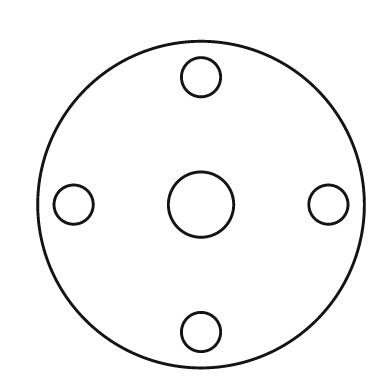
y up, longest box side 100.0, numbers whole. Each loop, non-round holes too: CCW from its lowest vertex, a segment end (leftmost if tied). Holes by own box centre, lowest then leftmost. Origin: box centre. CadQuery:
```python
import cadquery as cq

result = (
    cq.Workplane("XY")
    .moveTo(0.0, 0.0)
    .circle(50.0)
    .moveTo(0.0, -39.0)
    .circle(6.0)
    .moveTo(-39.0, 0.0)
    .circle(6.0)
    .moveTo(0.0, 0.0)
    .circle(10.0)
    .moveTo(39.0, 0.0)
    .circle(6.0)
    .moveTo(0.0, 39.0)
    .circle(6.0)
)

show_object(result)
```